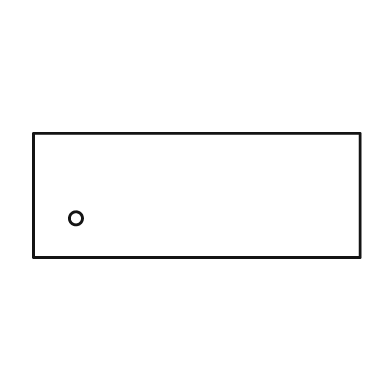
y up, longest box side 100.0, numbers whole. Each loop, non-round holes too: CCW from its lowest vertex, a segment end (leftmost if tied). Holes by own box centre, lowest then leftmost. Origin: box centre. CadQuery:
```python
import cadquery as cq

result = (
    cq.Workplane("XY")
    .moveTo(-50.0, -19.0)
    .lineTo(50.0, -19.0)
    .lineTo(50.0, 19.0)
    .lineTo(-50.0, 19.0)
    .close()
    .moveTo(-37.0, -7.0)
    .circle(2.0)
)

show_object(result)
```